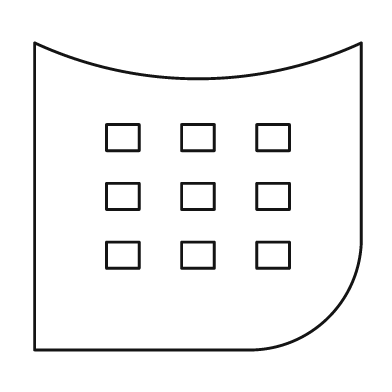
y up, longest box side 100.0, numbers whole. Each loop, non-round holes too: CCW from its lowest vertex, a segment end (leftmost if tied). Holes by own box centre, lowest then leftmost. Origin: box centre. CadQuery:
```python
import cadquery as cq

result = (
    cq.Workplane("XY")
    .moveTo(-50.0, -47.0)
    .lineTo(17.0, -47.0)
    .threePointArc((40.0, -37.0), (50.0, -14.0))
    .lineTo(50.0, 47.0)
    .threePointArc((0.0, 36.0), (-50.0, 47.0))
    .close()
    .moveTo(-28.0, -22.0)
    .lineTo(-18.0, -22.0)
    .lineTo(-18.0, -14.0)
    .lineTo(-28.0, -14.0)
    .close()
    .moveTo(-5.0, -22.0)
    .lineTo(5.0, -22.0)
    .lineTo(5.0, -14.0)
    .lineTo(-5.0, -14.0)
    .close()
    .moveTo(18.0, -22.0)
    .lineTo(28.0, -22.0)
    .lineTo(28.0, -14.0)
    .lineTo(18.0, -14.0)
    .close()
    .moveTo(-28.0, -4.0)
    .lineTo(-18.0, -4.0)
    .lineTo(-18.0, 4.0)
    .lineTo(-28.0, 4.0)
    .close()
    .moveTo(-5.0, -4.0)
    .lineTo(5.0, -4.0)
    .lineTo(5.0, 4.0)
    .lineTo(-5.0, 4.0)
    .close()
    .moveTo(18.0, -4.0)
    .lineTo(28.0, -4.0)
    .lineTo(28.0, 4.0)
    .lineTo(18.0, 4.0)
    .close()
    .moveTo(-28.0, 14.0)
    .lineTo(-18.0, 14.0)
    .lineTo(-18.0, 22.0)
    .lineTo(-28.0, 22.0)
    .close()
    .moveTo(-5.0, 14.0)
    .lineTo(5.0, 14.0)
    .lineTo(5.0, 22.0)
    .lineTo(-5.0, 22.0)
    .close()
    .moveTo(18.0, 14.0)
    .lineTo(28.0, 14.0)
    .lineTo(28.0, 22.0)
    .lineTo(18.0, 22.0)
    .close()
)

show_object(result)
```